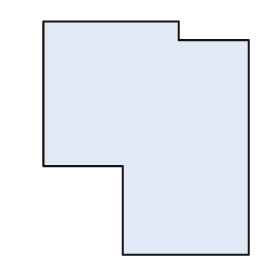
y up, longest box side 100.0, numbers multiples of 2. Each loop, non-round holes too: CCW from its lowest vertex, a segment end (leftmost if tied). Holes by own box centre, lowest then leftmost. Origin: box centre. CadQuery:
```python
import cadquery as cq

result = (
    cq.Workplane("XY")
    .moveTo(-10.0, -50.0)
    .lineTo(44.0, -50.0)
    .lineTo(44.0, 42.0)
    .lineTo(14.0, 42.0)
    .lineTo(14.0, 50.0)
    .lineTo(-44.0, 50.0)
    .lineTo(-44.0, -12.0)
    .lineTo(-10.0, -12.0)
    .close()
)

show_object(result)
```